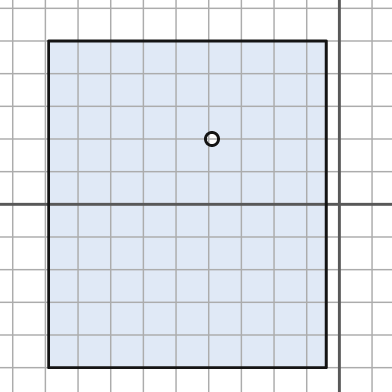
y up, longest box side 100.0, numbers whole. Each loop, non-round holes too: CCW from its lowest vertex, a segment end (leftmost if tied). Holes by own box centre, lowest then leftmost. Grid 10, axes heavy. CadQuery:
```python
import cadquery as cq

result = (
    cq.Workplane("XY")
    .moveTo(-89.0, -50.0)
    .lineTo(-4.0, -50.0)
    .lineTo(-4.0, 50.0)
    .lineTo(-89.0, 50.0)
    .close()
    .moveTo(-39.0, 20.0)
    .circle(2.0)
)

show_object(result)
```